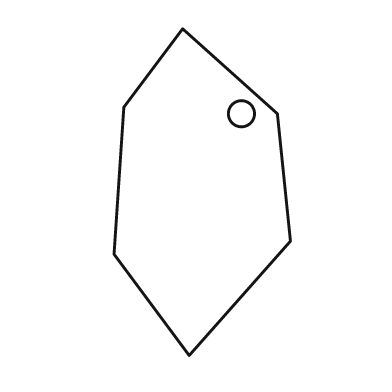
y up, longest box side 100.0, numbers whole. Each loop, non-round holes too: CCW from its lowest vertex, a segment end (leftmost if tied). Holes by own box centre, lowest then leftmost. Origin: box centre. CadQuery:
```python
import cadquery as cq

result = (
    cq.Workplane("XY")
    .moveTo(-4.0, -50.0)
    .lineTo(27.0, -15.0)
    .lineTo(23.0, 24.0)
    .lineTo(-6.0, 50.0)
    .lineTo(-24.0, 26.0)
    .lineTo(-27.0, -19.0)
    .close()
    .moveTo(12.0, 24.0)
    .circle(4.0)
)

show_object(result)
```